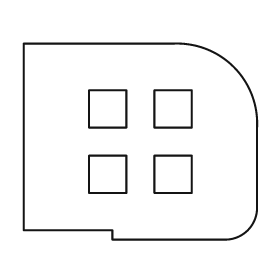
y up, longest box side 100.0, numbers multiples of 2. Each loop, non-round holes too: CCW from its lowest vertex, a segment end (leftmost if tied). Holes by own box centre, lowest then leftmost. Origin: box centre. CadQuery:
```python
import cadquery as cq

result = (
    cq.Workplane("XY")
    .moveTo(-12.0, -42.0)
    .lineTo(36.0, -42.0)
    .threePointArc((46.0, -38.0), (50.0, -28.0))
    .lineTo(50.0, 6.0)
    .threePointArc((40.0, 32.0), (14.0, 42.0))
    .lineTo(-50.0, 42.0)
    .lineTo(-50.0, -38.0)
    .lineTo(-12.0, -38.0)
    .close()
    .moveTo(-22.0, -22.0)
    .lineTo(-6.0, -22.0)
    .lineTo(-6.0, -6.0)
    .lineTo(-22.0, -6.0)
    .close()
    .moveTo(6.0, -22.0)
    .lineTo(22.0, -22.0)
    .lineTo(22.0, -6.0)
    .lineTo(6.0, -6.0)
    .close()
    .moveTo(-22.0, 6.0)
    .lineTo(-6.0, 6.0)
    .lineTo(-6.0, 22.0)
    .lineTo(-22.0, 22.0)
    .close()
    .moveTo(6.0, 6.0)
    .lineTo(22.0, 6.0)
    .lineTo(22.0, 22.0)
    .lineTo(6.0, 22.0)
    .close()
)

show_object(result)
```